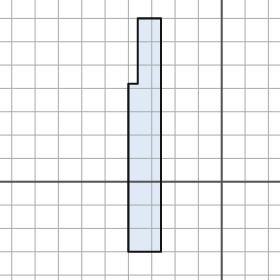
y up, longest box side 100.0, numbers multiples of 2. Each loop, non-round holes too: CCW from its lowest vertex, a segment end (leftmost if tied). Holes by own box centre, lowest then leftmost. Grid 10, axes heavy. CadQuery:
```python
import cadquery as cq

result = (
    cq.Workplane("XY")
    .moveTo(-40.0, -30.0)
    .lineTo(-26.0, -30.0)
    .lineTo(-26.0, 70.0)
    .lineTo(-36.0, 70.0)
    .lineTo(-36.0, 42.0)
    .lineTo(-40.0, 42.0)
    .close()
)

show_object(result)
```